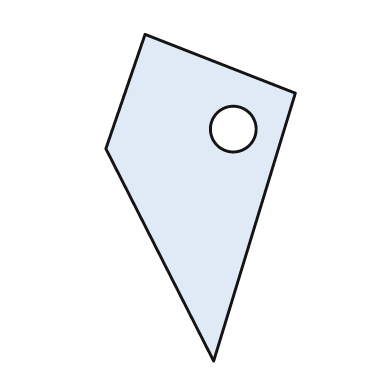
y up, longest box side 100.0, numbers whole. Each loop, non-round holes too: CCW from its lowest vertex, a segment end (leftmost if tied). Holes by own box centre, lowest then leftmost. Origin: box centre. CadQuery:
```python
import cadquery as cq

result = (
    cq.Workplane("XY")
    .moveTo(4.0, -50.0)
    .lineTo(29.0, 32.0)
    .lineTo(-17.0, 50.0)
    .lineTo(-29.0, 15.0)
    .close()
    .moveTo(10.0, 21.0)
    .circle(7.0)
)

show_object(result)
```